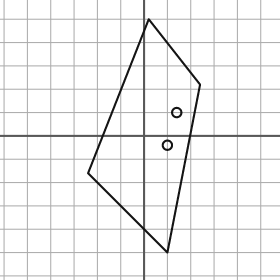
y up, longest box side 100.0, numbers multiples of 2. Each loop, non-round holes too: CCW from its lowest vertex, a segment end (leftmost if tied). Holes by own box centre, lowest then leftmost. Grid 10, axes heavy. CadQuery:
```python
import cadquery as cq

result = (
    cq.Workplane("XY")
    .moveTo(10.0, -50.0)
    .lineTo(24.0, 22.0)
    .lineTo(2.0, 50.0)
    .lineTo(-24.0, -16.0)
    .close()
    .moveTo(10.0, -4.0)
    .circle(2.0)
    .moveTo(14.0, 10.0)
    .circle(2.0)
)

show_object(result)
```